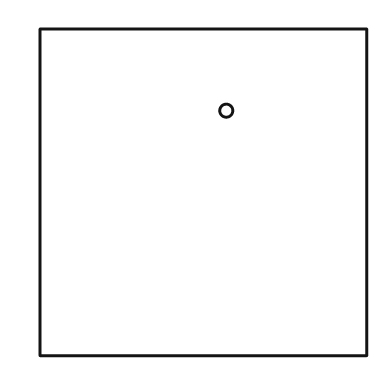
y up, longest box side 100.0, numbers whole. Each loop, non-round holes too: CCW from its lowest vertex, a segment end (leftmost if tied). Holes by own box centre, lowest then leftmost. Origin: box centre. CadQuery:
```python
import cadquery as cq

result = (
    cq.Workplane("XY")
    .moveTo(-50.0, -50.0)
    .lineTo(50.0, -50.0)
    .lineTo(50.0, 50.0)
    .lineTo(-50.0, 50.0)
    .close()
    .moveTo(7.0, 25.0)
    .circle(2.0)
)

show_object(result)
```